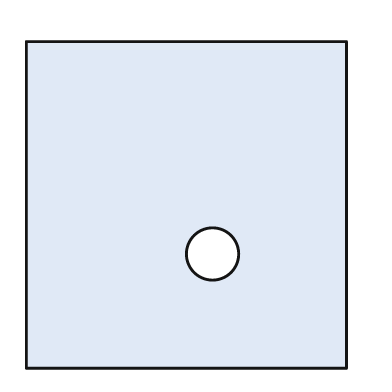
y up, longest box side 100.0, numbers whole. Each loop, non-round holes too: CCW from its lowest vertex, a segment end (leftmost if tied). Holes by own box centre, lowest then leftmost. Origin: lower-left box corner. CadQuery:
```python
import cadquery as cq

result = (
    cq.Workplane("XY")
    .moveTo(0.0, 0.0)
    .lineTo(98.0, 0.0)
    .lineTo(98.0, 100.0)
    .lineTo(0.0, 100.0)
    .close()
    .moveTo(57.0, 35.0)
    .circle(8.0)
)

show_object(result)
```